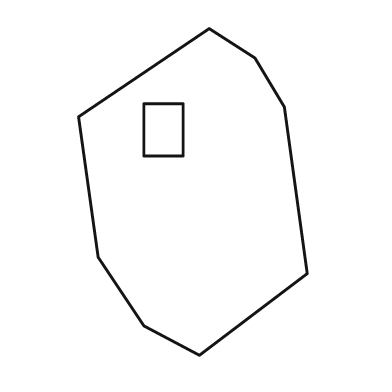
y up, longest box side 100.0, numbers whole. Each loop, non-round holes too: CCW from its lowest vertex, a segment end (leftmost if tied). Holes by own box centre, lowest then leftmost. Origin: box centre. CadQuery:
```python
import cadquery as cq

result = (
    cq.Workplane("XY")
    .moveTo(2.0, -50.0)
    .lineTo(35.0, -25.0)
    .lineTo(28.0, 26.0)
    .lineTo(19.0, 41.0)
    .lineTo(5.0, 50.0)
    .lineTo(-35.0, 23.0)
    .lineTo(-29.0, -20.0)
    .lineTo(-15.0, -41.0)
    .close()
    .moveTo(-15.0, 11.0)
    .lineTo(-3.0, 11.0)
    .lineTo(-3.0, 27.0)
    .lineTo(-15.0, 27.0)
    .close()
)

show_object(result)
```